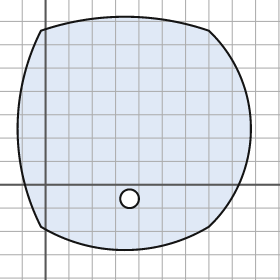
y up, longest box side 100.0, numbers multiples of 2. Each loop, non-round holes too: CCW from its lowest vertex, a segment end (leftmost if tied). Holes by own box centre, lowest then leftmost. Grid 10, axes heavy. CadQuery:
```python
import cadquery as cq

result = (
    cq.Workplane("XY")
    .moveTo(-2.0, -18.0)
    .threePointArc((34.0, -28.0), (70.0, -18.0))
    .threePointArc((88.0, 24.0), (70.0, 66.0))
    .threePointArc((34.0, 72.0), (-2.0, 66.0))
    .threePointArc((-12.0, 24.0), (-2.0, -18.0))
    .close()
    .moveTo(36.0, -6.0)
    .circle(4.0)
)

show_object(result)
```